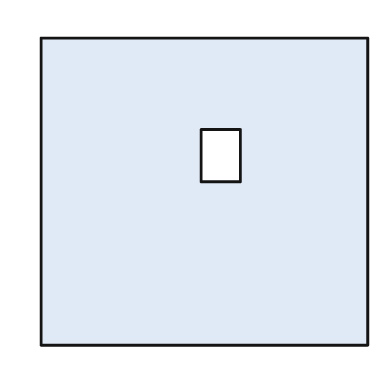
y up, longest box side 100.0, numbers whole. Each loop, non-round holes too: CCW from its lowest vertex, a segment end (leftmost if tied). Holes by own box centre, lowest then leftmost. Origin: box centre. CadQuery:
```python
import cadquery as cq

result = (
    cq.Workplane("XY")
    .moveTo(-50.0, -47.0)
    .lineTo(50.0, -47.0)
    .lineTo(50.0, 47.0)
    .lineTo(-50.0, 47.0)
    .close()
    .moveTo(-1.0, 3.0)
    .lineTo(11.0, 3.0)
    .lineTo(11.0, 19.0)
    .lineTo(-1.0, 19.0)
    .close()
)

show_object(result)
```